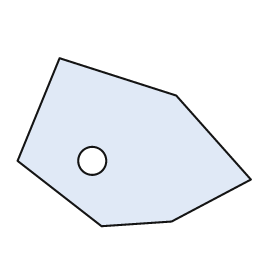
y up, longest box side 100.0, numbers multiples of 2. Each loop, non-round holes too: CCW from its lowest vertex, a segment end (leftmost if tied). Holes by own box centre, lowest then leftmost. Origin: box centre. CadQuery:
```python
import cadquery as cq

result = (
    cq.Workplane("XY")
    .moveTo(-14.0, -36.0)
    .lineTo(16.0, -34.0)
    .lineTo(50.0, -16.0)
    .lineTo(18.0, 20.0)
    .lineTo(-32.0, 36.0)
    .lineTo(-50.0, -8.0)
    .close()
    .moveTo(-18.0, -8.0)
    .circle(6.0)
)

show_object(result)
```